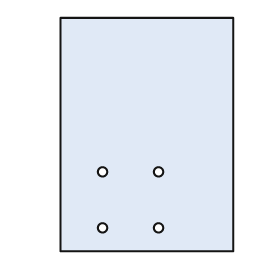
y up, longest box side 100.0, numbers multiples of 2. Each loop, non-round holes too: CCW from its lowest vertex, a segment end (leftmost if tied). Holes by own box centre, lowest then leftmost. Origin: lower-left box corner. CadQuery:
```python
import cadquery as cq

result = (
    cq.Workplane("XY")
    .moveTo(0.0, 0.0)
    .lineTo(74.0, 0.0)
    .lineTo(74.0, 100.0)
    .lineTo(0.0, 100.0)
    .close()
    .moveTo(18.0, 10.0)
    .circle(2.0)
    .moveTo(42.0, 10.0)
    .circle(2.0)
    .moveTo(18.0, 34.0)
    .circle(2.0)
    .moveTo(42.0, 34.0)
    .circle(2.0)
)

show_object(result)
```